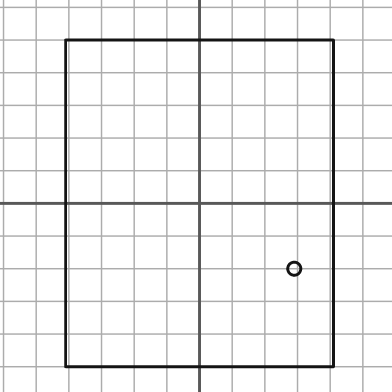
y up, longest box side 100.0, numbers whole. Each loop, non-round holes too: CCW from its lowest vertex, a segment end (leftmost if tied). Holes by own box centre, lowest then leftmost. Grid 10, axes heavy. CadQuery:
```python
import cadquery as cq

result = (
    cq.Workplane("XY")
    .moveTo(-41.0, -50.0)
    .lineTo(41.0, -50.0)
    .lineTo(41.0, 50.0)
    .lineTo(-41.0, 50.0)
    .close()
    .moveTo(29.0, -20.0)
    .circle(2.0)
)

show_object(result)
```